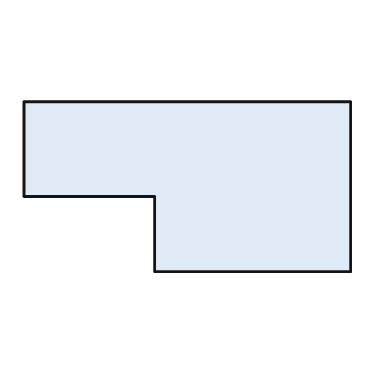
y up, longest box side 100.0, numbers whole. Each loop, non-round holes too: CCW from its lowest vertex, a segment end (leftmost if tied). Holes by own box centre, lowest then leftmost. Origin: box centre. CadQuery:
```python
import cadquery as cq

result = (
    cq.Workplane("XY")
    .moveTo(-10.0, -26.0)
    .lineTo(50.0, -26.0)
    .lineTo(50.0, 26.0)
    .lineTo(-50.0, 26.0)
    .lineTo(-50.0, -3.0)
    .lineTo(-10.0, -3.0)
    .close()
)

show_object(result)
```